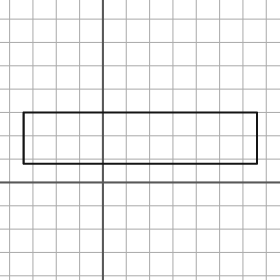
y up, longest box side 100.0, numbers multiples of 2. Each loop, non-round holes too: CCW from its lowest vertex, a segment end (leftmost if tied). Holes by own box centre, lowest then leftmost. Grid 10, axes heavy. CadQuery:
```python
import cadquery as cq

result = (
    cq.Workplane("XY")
    .moveTo(-34.0, 8.0)
    .lineTo(66.0, 8.0)
    .lineTo(66.0, 30.0)
    .lineTo(-34.0, 30.0)
    .close()
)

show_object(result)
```